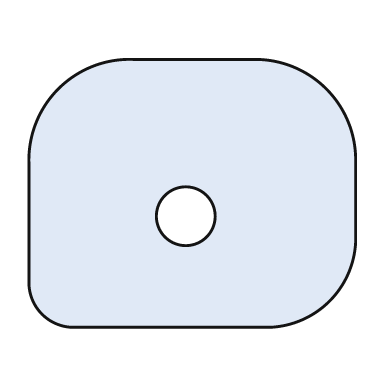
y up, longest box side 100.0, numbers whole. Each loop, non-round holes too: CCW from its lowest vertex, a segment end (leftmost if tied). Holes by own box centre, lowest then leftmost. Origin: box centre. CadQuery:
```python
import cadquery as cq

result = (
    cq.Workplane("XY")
    .moveTo(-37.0, -41.0)
    .lineTo(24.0, -41.0)
    .threePointArc((42.0, -33.0), (50.0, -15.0))
    .lineTo(50.0, 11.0)
    .threePointArc((41.0, 32.0), (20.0, 41.0))
    .lineTo(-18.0, 41.0)
    .threePointArc((-41.0, 32.0), (-50.0, 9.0))
    .lineTo(-50.0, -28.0)
    .threePointArc((-46.0, -37.0), (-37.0, -41.0))
    .close()
    .moveTo(-2.0, -7.0)
    .circle(9.0)
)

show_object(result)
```